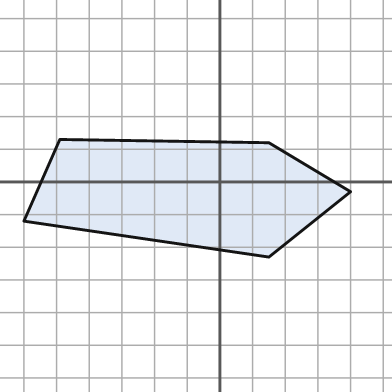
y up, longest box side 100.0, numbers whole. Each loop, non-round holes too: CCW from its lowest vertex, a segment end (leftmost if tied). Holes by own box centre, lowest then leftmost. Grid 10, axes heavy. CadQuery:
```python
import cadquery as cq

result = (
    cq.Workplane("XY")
    .moveTo(15.0, -23.0)
    .lineTo(40.0, -3.0)
    .lineTo(15.0, 12.0)
    .lineTo(-49.0, 13.0)
    .lineTo(-60.0, -12.0)
    .close()
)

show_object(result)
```